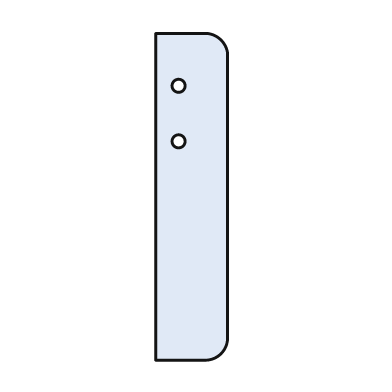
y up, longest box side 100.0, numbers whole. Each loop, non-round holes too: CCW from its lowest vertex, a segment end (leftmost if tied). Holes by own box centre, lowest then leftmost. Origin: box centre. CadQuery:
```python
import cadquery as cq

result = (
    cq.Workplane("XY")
    .moveTo(-11.0, -50.0)
    .lineTo(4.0, -50.0)
    .threePointArc((9.0, -48.0), (11.0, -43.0))
    .lineTo(11.0, 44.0)
    .threePointArc((9.0, 48.0), (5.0, 50.0))
    .lineTo(-11.0, 50.0)
    .close()
    .moveTo(-4.0, 17.0)
    .circle(2.0)
    .moveTo(-4.0, 34.0)
    .circle(2.0)
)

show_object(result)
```